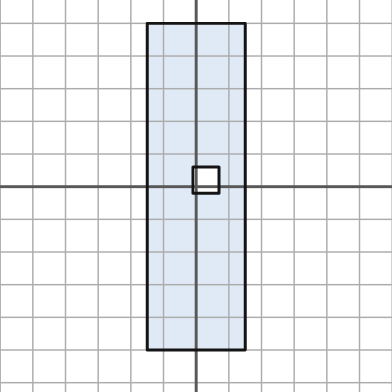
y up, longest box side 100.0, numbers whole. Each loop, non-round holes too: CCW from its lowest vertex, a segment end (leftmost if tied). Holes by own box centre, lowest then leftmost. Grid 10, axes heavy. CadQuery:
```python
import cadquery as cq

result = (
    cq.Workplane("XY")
    .moveTo(-15.0, -50.0)
    .lineTo(15.0, -50.0)
    .lineTo(15.0, 50.0)
    .lineTo(-15.0, 50.0)
    .close()
    .moveTo(-1.0, -2.0)
    .lineTo(7.0, -2.0)
    .lineTo(7.0, 6.0)
    .lineTo(-1.0, 6.0)
    .close()
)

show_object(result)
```